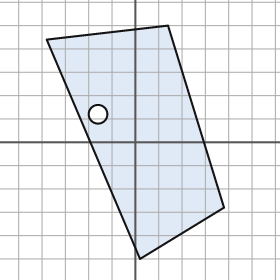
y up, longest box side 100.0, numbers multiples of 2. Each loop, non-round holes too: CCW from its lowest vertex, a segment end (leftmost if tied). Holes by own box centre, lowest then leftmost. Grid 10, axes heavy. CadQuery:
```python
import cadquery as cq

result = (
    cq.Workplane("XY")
    .moveTo(2.0, -50.0)
    .lineTo(38.0, -28.0)
    .lineTo(14.0, 50.0)
    .lineTo(-38.0, 44.0)
    .close()
    .moveTo(-16.0, 12.0)
    .circle(4.0)
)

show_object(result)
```